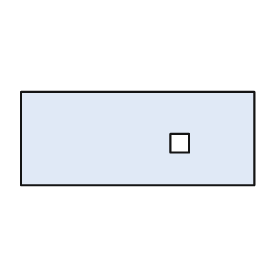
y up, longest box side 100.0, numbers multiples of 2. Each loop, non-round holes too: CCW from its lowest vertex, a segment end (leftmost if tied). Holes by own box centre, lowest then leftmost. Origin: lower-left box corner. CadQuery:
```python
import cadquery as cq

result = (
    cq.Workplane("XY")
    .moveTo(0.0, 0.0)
    .lineTo(100.0, 0.0)
    .lineTo(100.0, 40.0)
    .lineTo(0.0, 40.0)
    .close()
    .moveTo(64.0, 14.0)
    .lineTo(72.0, 14.0)
    .lineTo(72.0, 22.0)
    .lineTo(64.0, 22.0)
    .close()
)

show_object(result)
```